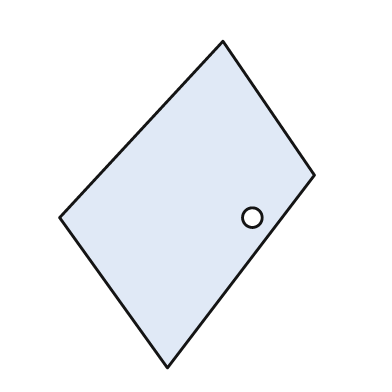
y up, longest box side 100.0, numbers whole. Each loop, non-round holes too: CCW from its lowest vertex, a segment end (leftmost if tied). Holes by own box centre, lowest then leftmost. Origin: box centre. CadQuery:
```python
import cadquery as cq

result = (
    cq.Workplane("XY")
    .moveTo(-6.0, -50.0)
    .lineTo(39.0, 9.0)
    .lineTo(11.0, 50.0)
    .lineTo(-39.0, -4.0)
    .close()
    .moveTo(20.0, -4.0)
    .circle(3.0)
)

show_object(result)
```